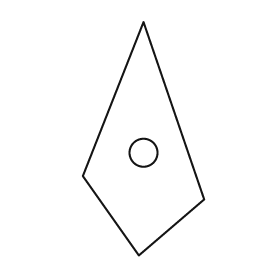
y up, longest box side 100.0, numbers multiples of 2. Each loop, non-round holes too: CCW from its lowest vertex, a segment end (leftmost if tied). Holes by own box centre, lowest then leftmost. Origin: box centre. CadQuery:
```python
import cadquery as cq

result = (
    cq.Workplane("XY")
    .moveTo(-2.0, -50.0)
    .lineTo(26.0, -26.0)
    .lineTo(0.0, 50.0)
    .lineTo(-26.0, -16.0)
    .close()
    .moveTo(0.0, -6.0)
    .circle(6.0)
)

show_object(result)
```